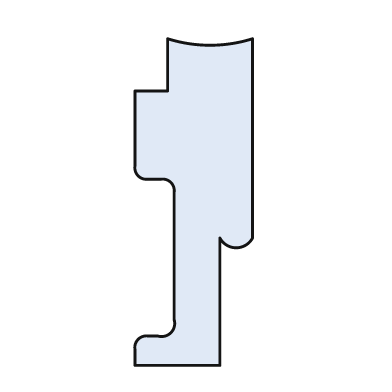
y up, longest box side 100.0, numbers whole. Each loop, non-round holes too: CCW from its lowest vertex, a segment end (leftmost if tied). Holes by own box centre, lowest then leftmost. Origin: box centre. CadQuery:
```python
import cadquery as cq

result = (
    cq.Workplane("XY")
    .moveTo(-18.0, -50.0)
    .lineTo(8.0, -50.0)
    .lineTo(8.0, -11.0)
    .threePointArc((13.0, -14.0), (18.0, -11.0))
    .lineTo(18.0, 50.0)
    .threePointArc((5.0, 48.0), (-8.0, 50.0))
    .lineTo(-8.0, 34.0)
    .lineTo(-18.0, 34.0)
    .lineTo(-18.0, 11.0)
    .threePointArc((-17.0, 8.0), (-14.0, 7.0))
    .lineTo(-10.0, 7.0)
    .threePointArc((-7.0, 6.0), (-6.0, 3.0))
    .lineTo(-6.0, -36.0)
    .threePointArc((-7.0, -40.0), (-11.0, -41.0))
    .lineTo(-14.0, -41.0)
    .threePointArc((-17.0, -42.0), (-18.0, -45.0))
    .close()
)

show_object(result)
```